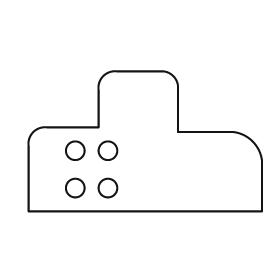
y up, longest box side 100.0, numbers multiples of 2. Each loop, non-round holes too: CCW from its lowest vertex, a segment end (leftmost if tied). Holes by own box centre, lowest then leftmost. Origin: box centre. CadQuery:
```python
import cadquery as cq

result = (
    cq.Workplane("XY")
    .moveTo(-50.0, -30.0)
    .lineTo(50.0, -30.0)
    .lineTo(50.0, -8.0)
    .threePointArc((46.0, 0.0), (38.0, 4.0))
    .lineTo(14.0, 4.0)
    .lineTo(14.0, 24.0)
    .threePointArc((12.0, 28.0), (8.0, 30.0))
    .lineTo(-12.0, 30.0)
    .threePointArc((-18.0, 28.0), (-20.0, 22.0))
    .lineTo(-20.0, 6.0)
    .lineTo(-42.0, 6.0)
    .threePointArc((-48.0, 4.0), (-50.0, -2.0))
    .close()
    .moveTo(-30.0, -20.0)
    .circle(4.0)
    .moveTo(-16.0, -20.0)
    .circle(4.0)
    .moveTo(-30.0, -4.0)
    .circle(4.0)
    .moveTo(-16.0, -4.0)
    .circle(4.0)
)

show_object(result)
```